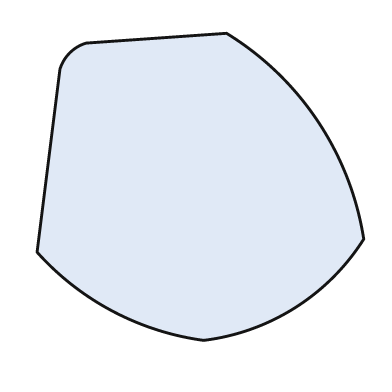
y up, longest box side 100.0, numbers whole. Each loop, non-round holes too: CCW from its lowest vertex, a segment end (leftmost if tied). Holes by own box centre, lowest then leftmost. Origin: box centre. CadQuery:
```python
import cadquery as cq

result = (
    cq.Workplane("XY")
    .moveTo(1.0, -47.0)
    .threePointArc((29.0, -37.0), (50.0, -16.0))
    .threePointArc((36.0, 20.0), (8.0, 47.0))
    .lineTo(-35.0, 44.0)
    .threePointArc((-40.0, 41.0), (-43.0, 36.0))
    .lineTo(-50.0, -20.0)
    .threePointArc((-27.0, -38.0), (1.0, -47.0))
    .close()
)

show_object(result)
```